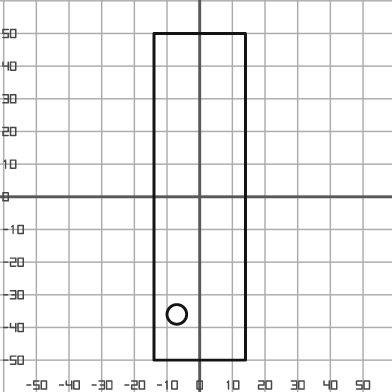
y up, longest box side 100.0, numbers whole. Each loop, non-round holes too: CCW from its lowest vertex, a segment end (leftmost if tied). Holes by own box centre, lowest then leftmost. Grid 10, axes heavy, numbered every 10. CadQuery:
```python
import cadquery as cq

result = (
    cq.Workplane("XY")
    .moveTo(-14.0, -50.0)
    .lineTo(14.0, -50.0)
    .lineTo(14.0, 50.0)
    .lineTo(-14.0, 50.0)
    .close()
    .moveTo(-7.0, -36.0)
    .circle(3.0)
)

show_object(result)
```